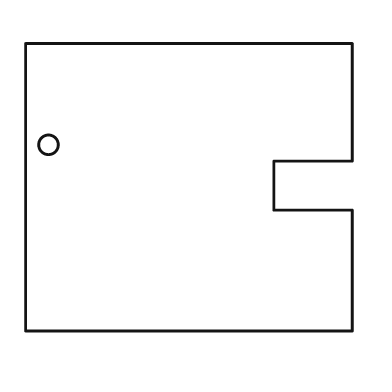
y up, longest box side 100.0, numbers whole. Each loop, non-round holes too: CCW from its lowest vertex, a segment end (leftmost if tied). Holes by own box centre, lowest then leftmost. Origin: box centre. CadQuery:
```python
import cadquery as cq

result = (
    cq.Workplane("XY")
    .moveTo(-50.0, -44.0)
    .lineTo(50.0, -44.0)
    .lineTo(50.0, -7.0)
    .lineTo(26.0, -7.0)
    .lineTo(26.0, 8.0)
    .lineTo(50.0, 8.0)
    .lineTo(50.0, 44.0)
    .lineTo(-50.0, 44.0)
    .close()
    .moveTo(-43.0, 13.0)
    .circle(3.0)
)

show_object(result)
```